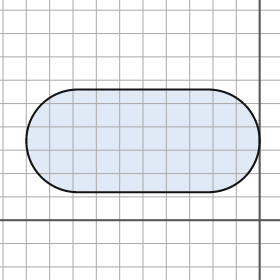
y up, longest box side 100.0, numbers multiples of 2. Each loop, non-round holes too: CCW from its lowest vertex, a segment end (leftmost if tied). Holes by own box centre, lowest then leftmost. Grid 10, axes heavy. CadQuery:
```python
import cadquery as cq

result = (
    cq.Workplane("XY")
    .moveTo(-78.0, 12.0)
    .lineTo(-22.0, 12.0)
    .threePointArc((0.0, 34.0), (-22.0, 56.0))
    .lineTo(-78.0, 56.0)
    .threePointArc((-100.0, 34.0), (-78.0, 12.0))
    .close()
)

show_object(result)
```